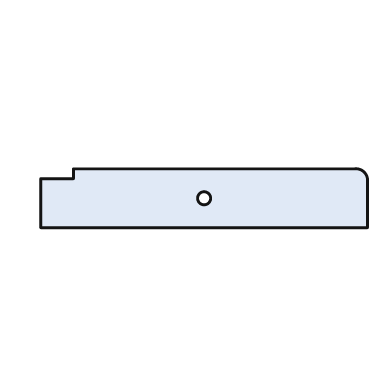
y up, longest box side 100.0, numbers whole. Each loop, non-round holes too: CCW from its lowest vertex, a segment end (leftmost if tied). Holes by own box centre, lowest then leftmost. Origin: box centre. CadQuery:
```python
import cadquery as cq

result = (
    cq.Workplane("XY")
    .moveTo(-50.0, -9.0)
    .lineTo(50.0, -9.0)
    .lineTo(50.0, 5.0)
    .threePointArc((49.0, 8.0), (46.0, 9.0))
    .lineTo(-40.0, 9.0)
    .lineTo(-40.0, 6.0)
    .lineTo(-50.0, 6.0)
    .close()
    .moveTo(0.0, 0.0)
    .circle(2.0)
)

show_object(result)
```